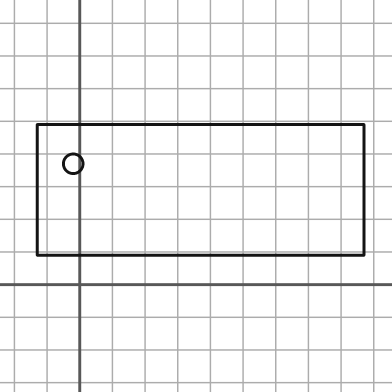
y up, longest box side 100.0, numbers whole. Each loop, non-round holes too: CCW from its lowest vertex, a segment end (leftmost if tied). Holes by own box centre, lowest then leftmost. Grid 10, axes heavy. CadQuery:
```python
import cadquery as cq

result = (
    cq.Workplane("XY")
    .moveTo(-13.0, 9.0)
    .lineTo(87.0, 9.0)
    .lineTo(87.0, 49.0)
    .lineTo(-13.0, 49.0)
    .close()
    .moveTo(-2.0, 37.0)
    .circle(3.0)
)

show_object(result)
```